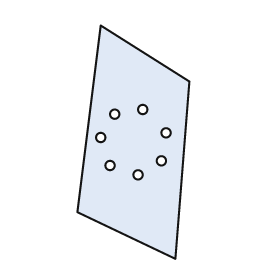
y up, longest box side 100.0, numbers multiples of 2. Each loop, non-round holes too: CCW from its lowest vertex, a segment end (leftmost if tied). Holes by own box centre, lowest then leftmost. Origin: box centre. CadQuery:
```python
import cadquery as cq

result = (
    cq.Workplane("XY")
    .moveTo(18.0, -50.0)
    .lineTo(24.0, 26.0)
    .lineTo(-14.0, 50.0)
    .lineTo(-24.0, -30.0)
    .close()
    .moveTo(2.0, -14.0)
    .circle(2.0)
    .moveTo(-10.0, -10.0)
    .circle(2.0)
    .moveTo(12.0, -8.0)
    .circle(2.0)
    .moveTo(-14.0, 2.0)
    .circle(2.0)
    .moveTo(14.0, 4.0)
    .circle(2.0)
    .moveTo(-8.0, 12.0)
    .circle(2.0)
    .moveTo(4.0, 14.0)
    .circle(2.0)
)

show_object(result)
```